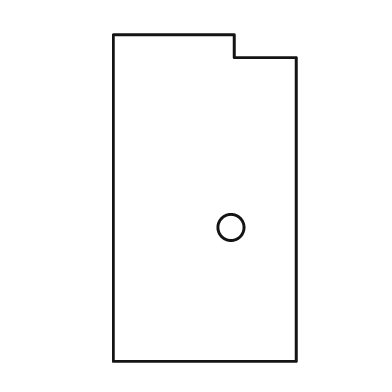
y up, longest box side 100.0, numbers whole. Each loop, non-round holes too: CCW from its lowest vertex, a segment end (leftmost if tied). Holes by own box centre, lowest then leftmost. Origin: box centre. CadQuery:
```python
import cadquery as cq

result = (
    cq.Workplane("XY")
    .moveTo(-28.0, -50.0)
    .lineTo(28.0, -50.0)
    .lineTo(28.0, 43.0)
    .lineTo(9.0, 43.0)
    .lineTo(9.0, 50.0)
    .lineTo(-28.0, 50.0)
    .close()
    .moveTo(8.0, -9.0)
    .circle(4.0)
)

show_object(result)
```